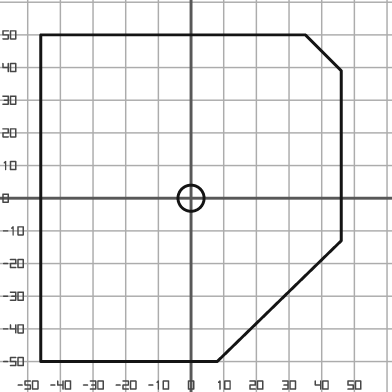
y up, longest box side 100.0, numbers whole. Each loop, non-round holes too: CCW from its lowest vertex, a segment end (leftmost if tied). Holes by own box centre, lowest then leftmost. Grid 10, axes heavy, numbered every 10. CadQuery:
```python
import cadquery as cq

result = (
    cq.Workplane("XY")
    .moveTo(-46.0, -50.0)
    .lineTo(8.0, -50.0)
    .lineTo(46.0, -13.0)
    .lineTo(46.0, 39.0)
    .lineTo(35.0, 50.0)
    .lineTo(-46.0, 50.0)
    .close()
    .moveTo(0.0, 0.0)
    .circle(4.0)
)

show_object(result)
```